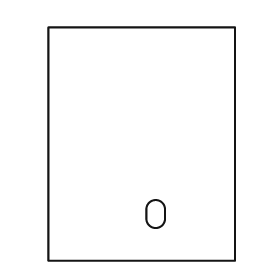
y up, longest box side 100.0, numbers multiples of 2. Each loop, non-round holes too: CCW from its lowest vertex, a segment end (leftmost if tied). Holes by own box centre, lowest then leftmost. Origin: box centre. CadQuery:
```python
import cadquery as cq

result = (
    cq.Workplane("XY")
    .moveTo(-40.0, -50.0)
    .lineTo(40.0, -50.0)
    .lineTo(40.0, 50.0)
    .lineTo(-40.0, 50.0)
    .close()
    .moveTo(2.0, -32.0)
    .threePointArc((6.0, -36.0), (10.0, -32.0))
    .lineTo(10.0, -28.0)
    .threePointArc((6.0, -24.0), (2.0, -28.0))
    .close()
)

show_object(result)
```